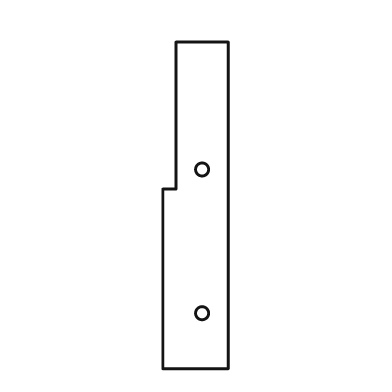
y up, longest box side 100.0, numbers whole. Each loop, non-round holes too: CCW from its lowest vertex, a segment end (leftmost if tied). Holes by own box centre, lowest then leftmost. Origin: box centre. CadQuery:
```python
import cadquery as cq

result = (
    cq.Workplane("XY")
    .moveTo(-10.0, -50.0)
    .lineTo(10.0, -50.0)
    .lineTo(10.0, 50.0)
    .lineTo(-6.0, 50.0)
    .lineTo(-6.0, 5.0)
    .lineTo(-10.0, 5.0)
    .close()
    .moveTo(2.0, -33.0)
    .circle(2.0)
    .moveTo(2.0, 11.0)
    .circle(2.0)
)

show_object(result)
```